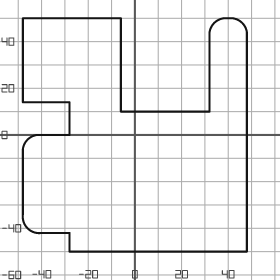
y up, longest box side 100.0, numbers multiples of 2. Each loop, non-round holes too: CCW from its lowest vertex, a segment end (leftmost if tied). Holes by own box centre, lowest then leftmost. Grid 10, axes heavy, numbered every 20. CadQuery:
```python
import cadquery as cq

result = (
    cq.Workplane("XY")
    .moveTo(-28.0, -50.0)
    .lineTo(48.0, -50.0)
    .lineTo(48.0, 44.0)
    .threePointArc((46.0, 48.0), (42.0, 50.0))
    .lineTo(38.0, 50.0)
    .threePointArc((34.0, 48.0), (32.0, 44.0))
    .lineTo(32.0, 10.0)
    .lineTo(-6.0, 10.0)
    .lineTo(-6.0, 50.0)
    .lineTo(-48.0, 50.0)
    .lineTo(-48.0, 14.0)
    .lineTo(-28.0, 14.0)
    .lineTo(-28.0, 0.0)
    .lineTo(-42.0, 0.0)
    .threePointArc((-46.0, -2.0), (-48.0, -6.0))
    .lineTo(-48.0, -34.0)
    .threePointArc((-46.0, -40.0), (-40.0, -42.0))
    .lineTo(-28.0, -42.0)
    .close()
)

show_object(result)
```